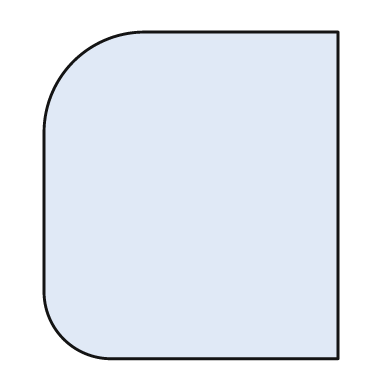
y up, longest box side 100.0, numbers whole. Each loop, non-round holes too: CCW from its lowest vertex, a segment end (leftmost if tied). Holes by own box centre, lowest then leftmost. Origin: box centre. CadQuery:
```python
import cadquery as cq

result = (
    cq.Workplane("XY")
    .moveTo(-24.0, -50.0)
    .lineTo(45.0, -50.0)
    .lineTo(45.0, 50.0)
    .lineTo(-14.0, 50.0)
    .threePointArc((-36.0, 41.0), (-45.0, 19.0))
    .lineTo(-45.0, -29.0)
    .threePointArc((-39.0, -44.0), (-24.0, -50.0))
    .close()
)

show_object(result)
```